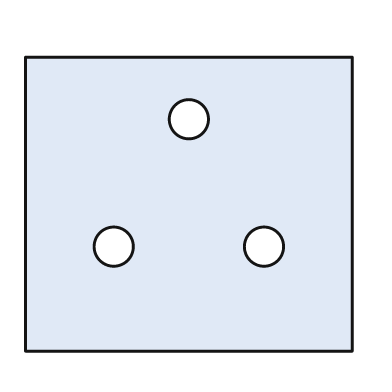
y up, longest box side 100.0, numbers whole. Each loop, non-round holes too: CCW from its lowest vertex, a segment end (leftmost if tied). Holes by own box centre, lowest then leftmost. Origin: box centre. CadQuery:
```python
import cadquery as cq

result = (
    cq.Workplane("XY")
    .moveTo(-50.0, -45.0)
    .lineTo(50.0, -45.0)
    .lineTo(50.0, 45.0)
    .lineTo(-50.0, 45.0)
    .close()
    .moveTo(-23.0, -13.0)
    .circle(6.0)
    .moveTo(23.0, -13.0)
    .circle(6.0)
    .moveTo(0.0, 26.0)
    .circle(6.0)
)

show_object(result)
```